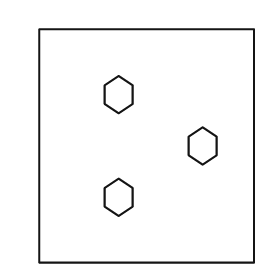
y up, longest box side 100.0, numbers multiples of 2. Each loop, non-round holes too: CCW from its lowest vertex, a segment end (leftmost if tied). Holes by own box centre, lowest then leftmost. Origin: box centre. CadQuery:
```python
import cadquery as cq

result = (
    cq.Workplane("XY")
    .moveTo(-46.0, -50.0)
    .lineTo(46.0, -50.0)
    .lineTo(46.0, 50.0)
    .lineTo(-46.0, 50.0)
    .close()
    .moveTo(-12.0, -30.0)
    .lineTo(-6.0, -26.0)
    .lineTo(-6.0, -18.0)
    .lineTo(-12.0, -14.0)
    .lineTo(-18.0, -18.0)
    .lineTo(-18.0, -26.0)
    .close()
    .moveTo(24.0, -8.0)
    .lineTo(30.0, -4.0)
    .lineTo(30.0, 4.0)
    .lineTo(24.0, 8.0)
    .lineTo(18.0, 4.0)
    .lineTo(18.0, -4.0)
    .close()
    .moveTo(-12.0, 14.0)
    .lineTo(-6.0, 18.0)
    .lineTo(-6.0, 26.0)
    .lineTo(-12.0, 30.0)
    .lineTo(-18.0, 26.0)
    .lineTo(-18.0, 18.0)
    .close()
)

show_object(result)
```